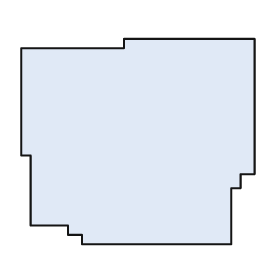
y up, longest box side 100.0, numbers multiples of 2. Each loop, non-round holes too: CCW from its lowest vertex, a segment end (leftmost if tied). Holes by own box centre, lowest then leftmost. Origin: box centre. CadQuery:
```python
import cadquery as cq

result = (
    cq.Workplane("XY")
    .moveTo(-24.0, -44.0)
    .lineTo(40.0, -44.0)
    .lineTo(40.0, -20.0)
    .lineTo(44.0, -20.0)
    .lineTo(44.0, -14.0)
    .lineTo(50.0, -14.0)
    .lineTo(50.0, 44.0)
    .lineTo(-6.0, 44.0)
    .lineTo(-6.0, 40.0)
    .lineTo(-50.0, 40.0)
    .lineTo(-50.0, -6.0)
    .lineTo(-46.0, -6.0)
    .lineTo(-46.0, -36.0)
    .lineTo(-30.0, -36.0)
    .lineTo(-30.0, -40.0)
    .lineTo(-24.0, -40.0)
    .close()
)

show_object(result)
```